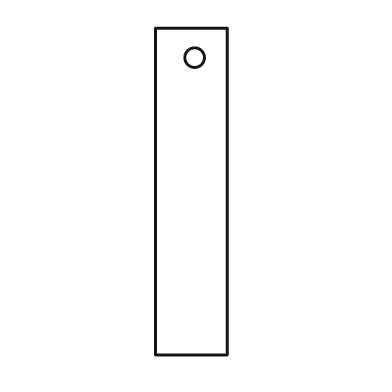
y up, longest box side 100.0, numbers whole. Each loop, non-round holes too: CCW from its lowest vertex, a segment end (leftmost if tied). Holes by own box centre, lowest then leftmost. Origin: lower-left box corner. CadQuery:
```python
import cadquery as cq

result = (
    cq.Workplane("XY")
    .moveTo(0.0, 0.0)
    .lineTo(22.0, 0.0)
    .lineTo(22.0, 100.0)
    .lineTo(0.0, 100.0)
    .close()
    .moveTo(12.0, 91.0)
    .circle(3.0)
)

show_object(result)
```